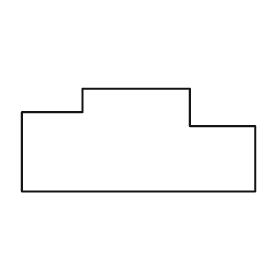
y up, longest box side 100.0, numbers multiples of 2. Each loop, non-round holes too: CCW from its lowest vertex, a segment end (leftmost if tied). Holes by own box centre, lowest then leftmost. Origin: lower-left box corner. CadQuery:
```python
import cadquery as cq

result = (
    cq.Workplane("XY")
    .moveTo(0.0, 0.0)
    .lineTo(100.0, 0.0)
    .lineTo(100.0, 28.0)
    .lineTo(72.0, 28.0)
    .lineTo(72.0, 44.0)
    .lineTo(26.0, 44.0)
    .lineTo(26.0, 34.0)
    .lineTo(0.0, 34.0)
    .close()
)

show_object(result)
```